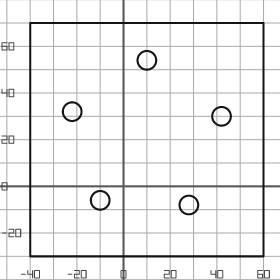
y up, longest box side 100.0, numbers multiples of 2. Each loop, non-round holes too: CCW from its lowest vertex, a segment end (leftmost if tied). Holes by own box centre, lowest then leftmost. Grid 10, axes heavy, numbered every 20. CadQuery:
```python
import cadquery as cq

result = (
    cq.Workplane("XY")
    .moveTo(-40.0, -30.0)
    .lineTo(60.0, -30.0)
    .lineTo(60.0, 70.0)
    .lineTo(-40.0, 70.0)
    .close()
    .moveTo(28.0, -8.0)
    .circle(4.0)
    .moveTo(-10.0, -6.0)
    .circle(4.0)
    .moveTo(42.0, 30.0)
    .circle(4.0)
    .moveTo(-22.0, 32.0)
    .circle(4.0)
    .moveTo(10.0, 54.0)
    .circle(4.0)
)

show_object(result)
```